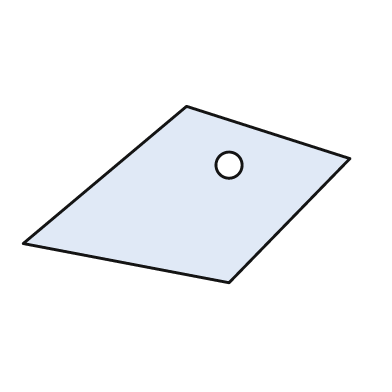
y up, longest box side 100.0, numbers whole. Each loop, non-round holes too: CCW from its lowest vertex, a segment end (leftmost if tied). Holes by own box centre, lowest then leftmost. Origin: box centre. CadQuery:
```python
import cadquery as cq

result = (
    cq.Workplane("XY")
    .moveTo(13.0, -27.0)
    .lineTo(50.0, 11.0)
    .lineTo(0.0, 27.0)
    .lineTo(-50.0, -15.0)
    .close()
    .moveTo(13.0, 9.0)
    .circle(4.0)
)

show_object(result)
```